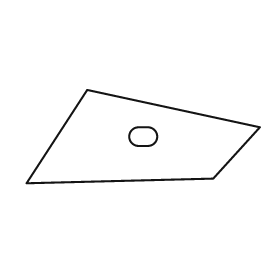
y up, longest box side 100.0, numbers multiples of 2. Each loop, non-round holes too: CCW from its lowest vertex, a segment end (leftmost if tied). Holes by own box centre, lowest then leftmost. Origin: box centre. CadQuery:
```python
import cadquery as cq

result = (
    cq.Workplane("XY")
    .moveTo(-50.0, -20.0)
    .lineTo(30.0, -18.0)
    .lineTo(50.0, 4.0)
    .lineTo(-24.0, 20.0)
    .close()
    .moveTo(-2.0, -4.0)
    .lineTo(2.0, -4.0)
    .threePointArc((6.0, 0.0), (2.0, 4.0))
    .lineTo(-2.0, 4.0)
    .threePointArc((-6.0, 0.0), (-2.0, -4.0))
    .close()
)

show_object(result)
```